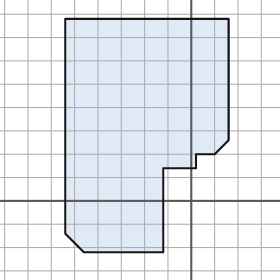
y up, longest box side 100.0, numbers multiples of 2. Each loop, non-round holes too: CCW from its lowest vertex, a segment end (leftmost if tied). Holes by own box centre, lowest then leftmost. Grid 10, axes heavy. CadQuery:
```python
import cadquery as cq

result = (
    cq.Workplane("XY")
    .moveTo(-46.0, -22.0)
    .lineTo(-12.0, -22.0)
    .lineTo(-12.0, 14.0)
    .lineTo(2.0, 14.0)
    .lineTo(2.0, 20.0)
    .lineTo(10.0, 20.0)
    .lineTo(16.0, 26.0)
    .lineTo(16.0, 78.0)
    .lineTo(-54.0, 78.0)
    .lineTo(-54.0, -14.0)
    .close()
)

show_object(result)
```